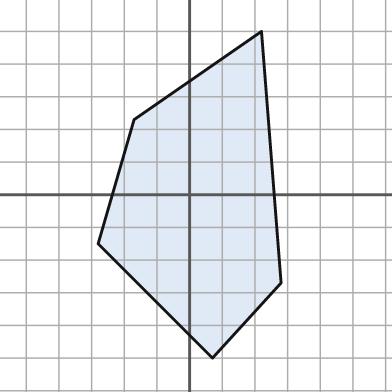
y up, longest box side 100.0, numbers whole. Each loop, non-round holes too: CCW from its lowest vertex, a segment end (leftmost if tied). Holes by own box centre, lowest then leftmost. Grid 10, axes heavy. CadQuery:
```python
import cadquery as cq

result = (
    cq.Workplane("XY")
    .moveTo(7.0, -50.0)
    .lineTo(28.0, -27.0)
    .lineTo(22.0, 50.0)
    .lineTo(-17.0, 23.0)
    .lineTo(-28.0, -15.0)
    .close()
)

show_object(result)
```